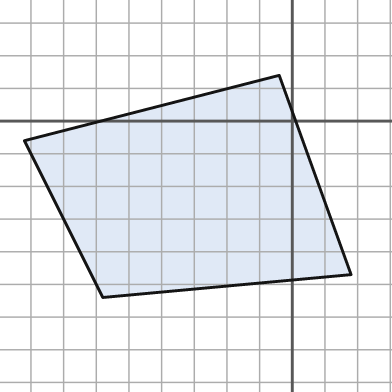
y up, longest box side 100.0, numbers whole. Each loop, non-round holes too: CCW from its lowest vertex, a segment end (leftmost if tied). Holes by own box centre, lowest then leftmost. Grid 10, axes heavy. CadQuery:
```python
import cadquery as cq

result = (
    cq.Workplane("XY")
    .moveTo(-58.0, -54.0)
    .lineTo(18.0, -47.0)
    .lineTo(-4.0, 14.0)
    .lineTo(-82.0, -6.0)
    .close()
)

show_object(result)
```